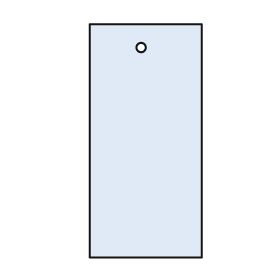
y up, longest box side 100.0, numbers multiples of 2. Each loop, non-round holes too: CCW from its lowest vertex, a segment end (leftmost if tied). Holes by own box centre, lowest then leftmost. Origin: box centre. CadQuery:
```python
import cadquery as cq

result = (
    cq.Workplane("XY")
    .moveTo(-24.0, -50.0)
    .lineTo(24.0, -50.0)
    .lineTo(24.0, 50.0)
    .lineTo(-24.0, 50.0)
    .close()
    .moveTo(-2.0, 40.0)
    .circle(2.0)
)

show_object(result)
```